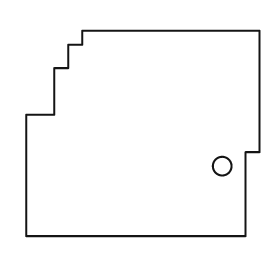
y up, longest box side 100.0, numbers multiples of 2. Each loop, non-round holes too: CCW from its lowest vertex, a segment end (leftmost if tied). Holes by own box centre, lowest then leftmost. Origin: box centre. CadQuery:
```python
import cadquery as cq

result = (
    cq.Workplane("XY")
    .moveTo(-50.0, -44.0)
    .lineTo(44.0, -44.0)
    .lineTo(44.0, -8.0)
    .lineTo(50.0, -8.0)
    .lineTo(50.0, 44.0)
    .lineTo(-26.0, 44.0)
    .lineTo(-26.0, 38.0)
    .lineTo(-32.0, 38.0)
    .lineTo(-32.0, 28.0)
    .lineTo(-38.0, 28.0)
    .lineTo(-38.0, 8.0)
    .lineTo(-50.0, 8.0)
    .close()
    .moveTo(34.0, -14.0)
    .circle(4.0)
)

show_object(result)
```